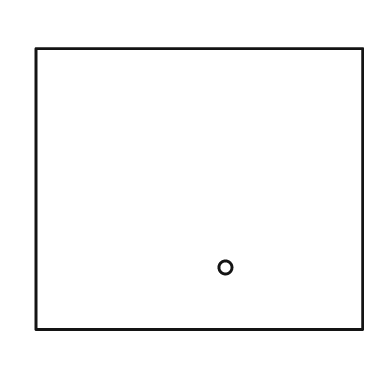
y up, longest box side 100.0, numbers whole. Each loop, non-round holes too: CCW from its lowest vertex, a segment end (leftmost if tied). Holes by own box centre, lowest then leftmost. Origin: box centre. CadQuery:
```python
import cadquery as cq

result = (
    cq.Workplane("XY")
    .moveTo(-50.0, -43.0)
    .lineTo(50.0, -43.0)
    .lineTo(50.0, 43.0)
    .lineTo(-50.0, 43.0)
    .close()
    .moveTo(8.0, -24.0)
    .circle(2.0)
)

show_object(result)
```